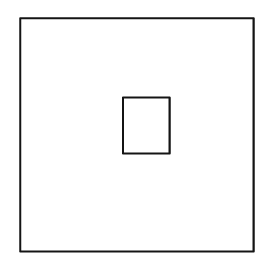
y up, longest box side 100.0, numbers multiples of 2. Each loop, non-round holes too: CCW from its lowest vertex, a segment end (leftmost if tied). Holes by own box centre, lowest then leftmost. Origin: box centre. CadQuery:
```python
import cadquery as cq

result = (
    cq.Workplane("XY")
    .moveTo(-50.0, -50.0)
    .lineTo(50.0, -50.0)
    .lineTo(50.0, 50.0)
    .lineTo(-50.0, 50.0)
    .close()
    .moveTo(-6.0, -8.0)
    .lineTo(14.0, -8.0)
    .lineTo(14.0, 16.0)
    .lineTo(-6.0, 16.0)
    .close()
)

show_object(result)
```